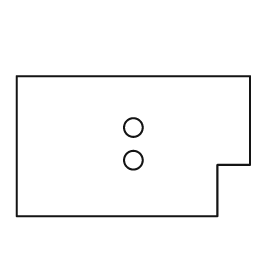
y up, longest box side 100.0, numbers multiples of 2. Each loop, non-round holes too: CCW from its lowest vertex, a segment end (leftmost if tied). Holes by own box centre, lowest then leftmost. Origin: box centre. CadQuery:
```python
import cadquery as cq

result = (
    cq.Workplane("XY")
    .moveTo(-50.0, -30.0)
    .lineTo(36.0, -30.0)
    .lineTo(36.0, -8.0)
    .lineTo(50.0, -8.0)
    .lineTo(50.0, 30.0)
    .lineTo(-50.0, 30.0)
    .close()
    .moveTo(0.0, -6.0)
    .circle(4.0)
    .moveTo(0.0, 8.0)
    .circle(4.0)
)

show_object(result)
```